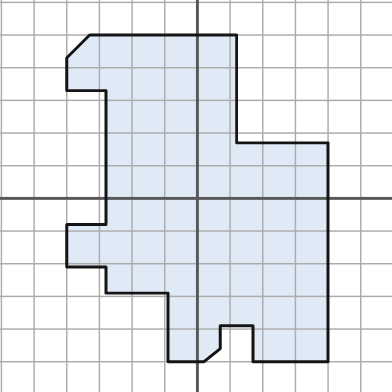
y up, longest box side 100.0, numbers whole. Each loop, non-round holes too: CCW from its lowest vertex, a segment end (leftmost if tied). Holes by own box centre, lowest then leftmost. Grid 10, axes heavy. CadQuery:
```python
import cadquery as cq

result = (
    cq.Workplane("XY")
    .moveTo(-9.0, -50.0)
    .lineTo(2.0, -50.0)
    .lineTo(7.0, -46.0)
    .lineTo(7.0, -39.0)
    .lineTo(17.0, -39.0)
    .lineTo(17.0, -50.0)
    .lineTo(40.0, -50.0)
    .lineTo(40.0, 17.0)
    .lineTo(12.0, 17.0)
    .lineTo(12.0, 50.0)
    .lineTo(-33.0, 50.0)
    .lineTo(-40.0, 43.0)
    .lineTo(-40.0, 33.0)
    .lineTo(-28.0, 33.0)
    .lineTo(-28.0, -8.0)
    .lineTo(-40.0, -8.0)
    .lineTo(-40.0, -21.0)
    .lineTo(-28.0, -21.0)
    .lineTo(-28.0, -29.0)
    .lineTo(-9.0, -29.0)
    .close()
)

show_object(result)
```